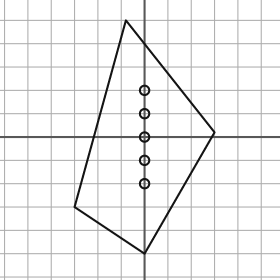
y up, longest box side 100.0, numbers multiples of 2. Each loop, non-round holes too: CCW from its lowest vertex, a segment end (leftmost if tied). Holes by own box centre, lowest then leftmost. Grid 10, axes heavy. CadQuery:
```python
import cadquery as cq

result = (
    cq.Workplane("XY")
    .moveTo(0.0, -50.0)
    .lineTo(30.0, 2.0)
    .lineTo(-8.0, 50.0)
    .lineTo(-30.0, -30.0)
    .close()
    .moveTo(0.0, -20.0)
    .circle(2.0)
    .moveTo(0.0, -10.0)
    .circle(2.0)
    .moveTo(0.0, 0.0)
    .circle(2.0)
    .moveTo(0.0, 10.0)
    .circle(2.0)
    .moveTo(0.0, 20.0)
    .circle(2.0)
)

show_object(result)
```